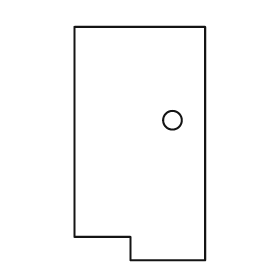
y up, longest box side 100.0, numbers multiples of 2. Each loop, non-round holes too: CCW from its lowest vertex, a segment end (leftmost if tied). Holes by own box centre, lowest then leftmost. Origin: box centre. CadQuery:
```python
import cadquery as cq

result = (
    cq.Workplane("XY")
    .moveTo(-4.0, -50.0)
    .lineTo(28.0, -50.0)
    .lineTo(28.0, 50.0)
    .lineTo(-28.0, 50.0)
    .lineTo(-28.0, -40.0)
    .lineTo(-4.0, -40.0)
    .close()
    .moveTo(14.0, 10.0)
    .circle(4.0)
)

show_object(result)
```